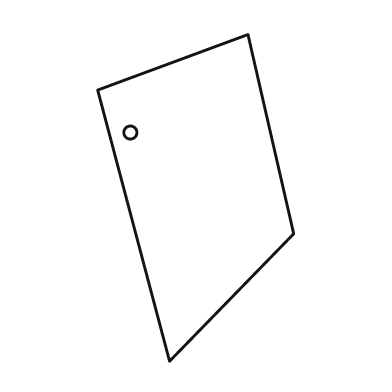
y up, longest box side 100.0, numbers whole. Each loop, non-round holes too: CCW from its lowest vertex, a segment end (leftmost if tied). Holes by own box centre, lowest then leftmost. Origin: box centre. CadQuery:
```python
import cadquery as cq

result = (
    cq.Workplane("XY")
    .moveTo(-8.0, -50.0)
    .lineTo(30.0, -11.0)
    .lineTo(16.0, 50.0)
    .lineTo(-30.0, 33.0)
    .close()
    .moveTo(-20.0, 20.0)
    .circle(2.0)
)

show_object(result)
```